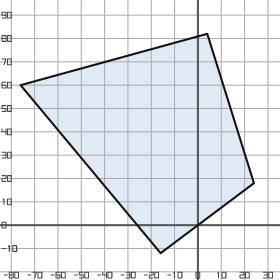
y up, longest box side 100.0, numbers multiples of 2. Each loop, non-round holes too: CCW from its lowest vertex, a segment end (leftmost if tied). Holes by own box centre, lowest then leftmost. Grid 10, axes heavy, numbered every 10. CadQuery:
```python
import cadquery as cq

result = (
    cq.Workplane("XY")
    .moveTo(-16.0, -12.0)
    .lineTo(24.0, 18.0)
    .lineTo(4.0, 82.0)
    .lineTo(-76.0, 60.0)
    .close()
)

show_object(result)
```